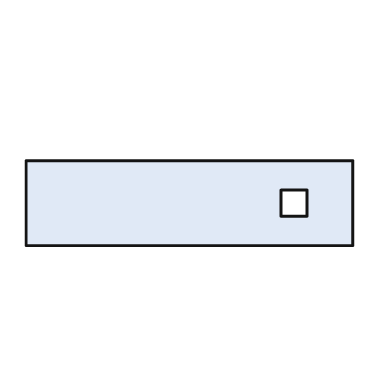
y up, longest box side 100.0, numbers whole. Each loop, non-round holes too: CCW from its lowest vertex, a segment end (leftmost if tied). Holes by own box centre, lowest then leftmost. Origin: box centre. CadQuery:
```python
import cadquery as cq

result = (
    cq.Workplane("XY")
    .moveTo(-50.0, -13.0)
    .lineTo(50.0, -13.0)
    .lineTo(50.0, 13.0)
    .lineTo(-50.0, 13.0)
    .close()
    .moveTo(28.0, -4.0)
    .lineTo(36.0, -4.0)
    .lineTo(36.0, 4.0)
    .lineTo(28.0, 4.0)
    .close()
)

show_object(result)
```